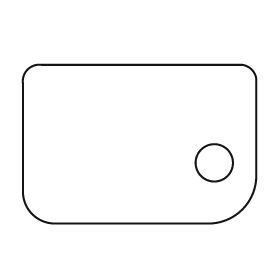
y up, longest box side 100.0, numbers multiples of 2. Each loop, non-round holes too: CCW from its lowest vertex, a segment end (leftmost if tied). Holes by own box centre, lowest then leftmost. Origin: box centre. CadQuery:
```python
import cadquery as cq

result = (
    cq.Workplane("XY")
    .moveTo(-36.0, -34.0)
    .lineTo(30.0, -34.0)
    .threePointArc((44.0, -28.0), (50.0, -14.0))
    .lineTo(50.0, 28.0)
    .threePointArc((48.0, 32.0), (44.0, 34.0))
    .lineTo(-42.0, 34.0)
    .threePointArc((-48.0, 32.0), (-50.0, 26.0))
    .lineTo(-50.0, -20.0)
    .threePointArc((-46.0, -30.0), (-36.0, -34.0))
    .close()
    .moveTo(32.0, -8.0)
    .circle(8.0)
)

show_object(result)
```